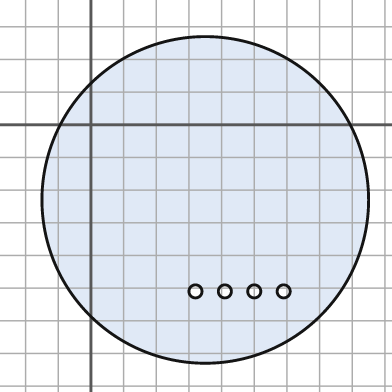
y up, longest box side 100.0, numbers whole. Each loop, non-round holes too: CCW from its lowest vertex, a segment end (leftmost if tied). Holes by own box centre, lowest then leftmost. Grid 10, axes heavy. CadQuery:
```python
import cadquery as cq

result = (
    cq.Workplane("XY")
    .moveTo(35.0, -23.0)
    .circle(50.0)
    .moveTo(32.0, -51.0)
    .circle(2.0)
    .moveTo(41.0, -51.0)
    .circle(2.0)
    .moveTo(50.0, -51.0)
    .circle(2.0)
    .moveTo(59.0, -51.0)
    .circle(2.0)
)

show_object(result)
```